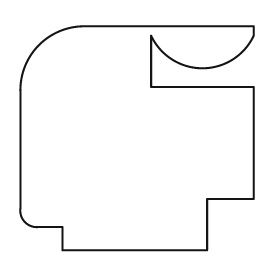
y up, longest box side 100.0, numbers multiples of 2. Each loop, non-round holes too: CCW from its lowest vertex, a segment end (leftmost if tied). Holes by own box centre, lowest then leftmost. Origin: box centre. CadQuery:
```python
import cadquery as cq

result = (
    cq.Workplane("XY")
    .moveTo(-32.0, -48.0)
    .lineTo(30.0, -48.0)
    .lineTo(30.0, -26.0)
    .lineTo(50.0, -26.0)
    .lineTo(50.0, 22.0)
    .lineTo(6.0, 22.0)
    .lineTo(6.0, 44.0)
    .threePointArc((28.0, 30.0), (50.0, 44.0))
    .lineTo(50.0, 48.0)
    .lineTo(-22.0, 48.0)
    .threePointArc((-42.0, 40.0), (-50.0, 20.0))
    .lineTo(-50.0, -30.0)
    .threePointArc((-48.0, -36.0), (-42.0, -38.0))
    .lineTo(-32.0, -38.0)
    .close()
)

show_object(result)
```